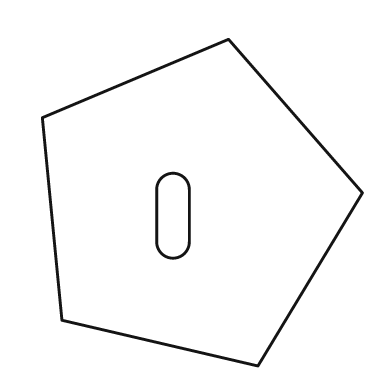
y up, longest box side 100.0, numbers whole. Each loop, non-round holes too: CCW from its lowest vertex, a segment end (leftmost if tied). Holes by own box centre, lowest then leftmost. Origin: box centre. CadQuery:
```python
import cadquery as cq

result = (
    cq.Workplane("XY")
    .moveTo(17.0, -50.0)
    .lineTo(49.0, 3.0)
    .lineTo(8.0, 50.0)
    .lineTo(-49.0, 26.0)
    .lineTo(-43.0, -36.0)
    .close()
    .moveTo(-14.0, -12.0)
    .threePointArc((-9.0, -17.0), (-4.0, -12.0))
    .lineTo(-4.0, 4.0)
    .threePointArc((-9.0, 9.0), (-14.0, 4.0))
    .close()
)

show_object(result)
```